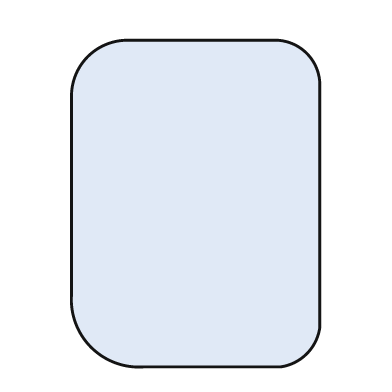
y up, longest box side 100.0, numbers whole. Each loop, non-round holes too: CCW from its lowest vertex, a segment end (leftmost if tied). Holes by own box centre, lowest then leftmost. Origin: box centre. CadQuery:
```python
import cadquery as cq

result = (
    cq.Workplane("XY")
    .moveTo(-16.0, -50.0)
    .lineTo(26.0, -50.0)
    .threePointArc((34.0, -46.0), (38.0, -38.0))
    .lineTo(38.0, 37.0)
    .threePointArc((34.0, 46.0), (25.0, 50.0))
    .lineTo(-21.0, 50.0)
    .threePointArc((-33.0, 45.0), (-38.0, 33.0))
    .lineTo(-38.0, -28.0)
    .threePointArc((-32.0, -44.0), (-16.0, -50.0))
    .close()
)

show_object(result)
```